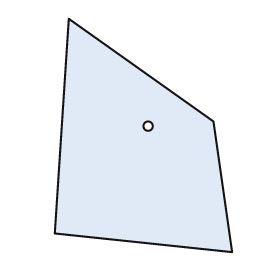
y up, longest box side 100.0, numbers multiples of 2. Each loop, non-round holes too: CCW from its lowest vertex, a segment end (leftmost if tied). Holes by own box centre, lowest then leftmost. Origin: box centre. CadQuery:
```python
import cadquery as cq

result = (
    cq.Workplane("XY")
    .moveTo(38.0, -50.0)
    .lineTo(30.0, 6.0)
    .lineTo(-32.0, 50.0)
    .lineTo(-38.0, -42.0)
    .close()
    .moveTo(2.0, 4.0)
    .circle(2.0)
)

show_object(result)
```